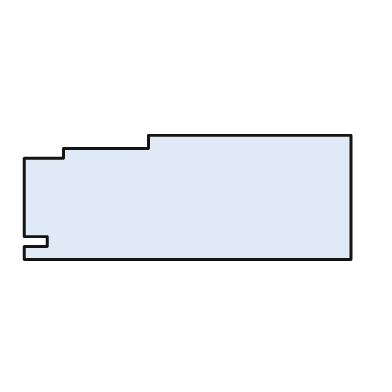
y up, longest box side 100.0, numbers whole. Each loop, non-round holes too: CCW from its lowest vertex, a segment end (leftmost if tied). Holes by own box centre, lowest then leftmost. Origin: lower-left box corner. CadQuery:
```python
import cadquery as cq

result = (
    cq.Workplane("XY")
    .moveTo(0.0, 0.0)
    .lineTo(100.0, 0.0)
    .lineTo(100.0, 38.0)
    .lineTo(38.0, 38.0)
    .lineTo(38.0, 34.0)
    .lineTo(12.0, 34.0)
    .lineTo(12.0, 31.0)
    .lineTo(0.0, 31.0)
    .lineTo(0.0, 7.0)
    .lineTo(7.0, 7.0)
    .lineTo(7.0, 4.0)
    .lineTo(0.0, 4.0)
    .close()
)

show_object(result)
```